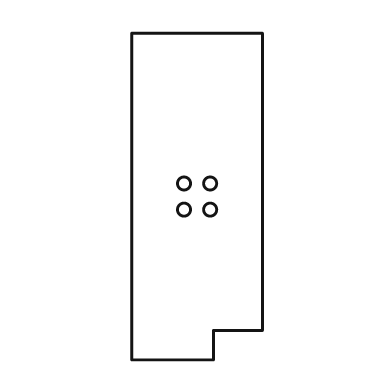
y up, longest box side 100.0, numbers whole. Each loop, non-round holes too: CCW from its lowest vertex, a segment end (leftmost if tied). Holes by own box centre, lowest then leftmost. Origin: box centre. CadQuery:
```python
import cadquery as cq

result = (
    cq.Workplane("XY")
    .moveTo(-20.0, -50.0)
    .lineTo(5.0, -50.0)
    .lineTo(5.0, -41.0)
    .lineTo(20.0, -41.0)
    .lineTo(20.0, 50.0)
    .lineTo(-20.0, 50.0)
    .close()
    .moveTo(-4.0, -4.0)
    .circle(2.0)
    .moveTo(4.0, -4.0)
    .circle(2.0)
    .moveTo(-4.0, 4.0)
    .circle(2.0)
    .moveTo(4.0, 4.0)
    .circle(2.0)
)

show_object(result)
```